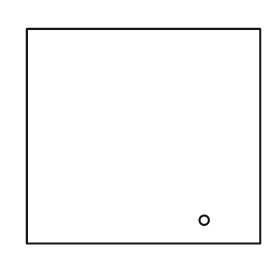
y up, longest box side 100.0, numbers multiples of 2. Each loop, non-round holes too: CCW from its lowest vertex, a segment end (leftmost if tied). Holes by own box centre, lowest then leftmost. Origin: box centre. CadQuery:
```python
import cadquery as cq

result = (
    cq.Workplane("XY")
    .moveTo(-50.0, -46.0)
    .lineTo(50.0, -46.0)
    .lineTo(50.0, 46.0)
    .lineTo(-50.0, 46.0)
    .close()
    .moveTo(26.0, -36.0)
    .circle(2.0)
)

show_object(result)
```